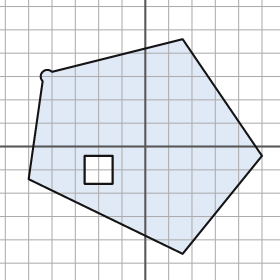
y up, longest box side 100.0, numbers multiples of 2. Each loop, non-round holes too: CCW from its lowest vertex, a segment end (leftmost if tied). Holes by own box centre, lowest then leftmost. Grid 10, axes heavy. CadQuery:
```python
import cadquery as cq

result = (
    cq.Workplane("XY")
    .moveTo(16.0, -46.0)
    .lineTo(50.0, -4.0)
    .lineTo(16.0, 46.0)
    .lineTo(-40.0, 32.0)
    .threePointArc((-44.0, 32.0), (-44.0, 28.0))
    .lineTo(-50.0, -14.0)
    .close()
    .moveTo(-26.0, -16.0)
    .lineTo(-14.0, -16.0)
    .lineTo(-14.0, -4.0)
    .lineTo(-26.0, -4.0)
    .close()
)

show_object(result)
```